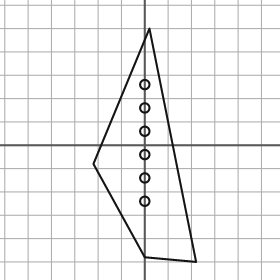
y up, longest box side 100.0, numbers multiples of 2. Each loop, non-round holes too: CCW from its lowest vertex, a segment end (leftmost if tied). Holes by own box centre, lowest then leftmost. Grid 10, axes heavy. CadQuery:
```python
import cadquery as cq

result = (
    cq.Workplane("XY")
    .moveTo(22.0, -50.0)
    .lineTo(2.0, 50.0)
    .lineTo(-22.0, -8.0)
    .lineTo(0.0, -48.0)
    .close()
    .moveTo(0.0, -24.0)
    .circle(2.0)
    .moveTo(0.0, -14.0)
    .circle(2.0)
    .moveTo(0.0, -4.0)
    .circle(2.0)
    .moveTo(0.0, 6.0)
    .circle(2.0)
    .moveTo(0.0, 16.0)
    .circle(2.0)
    .moveTo(0.0, 26.0)
    .circle(2.0)
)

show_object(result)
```